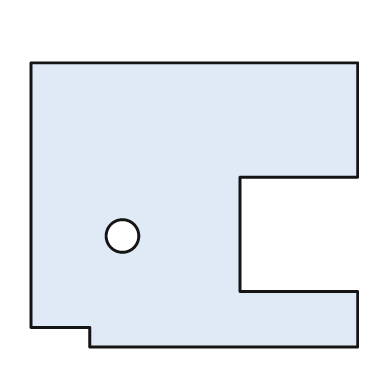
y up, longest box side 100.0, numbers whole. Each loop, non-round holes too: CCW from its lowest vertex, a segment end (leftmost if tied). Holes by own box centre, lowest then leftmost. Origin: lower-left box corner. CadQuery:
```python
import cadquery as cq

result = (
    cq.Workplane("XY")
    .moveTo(18.0, 0.0)
    .lineTo(100.0, 0.0)
    .lineTo(100.0, 17.0)
    .lineTo(64.0, 17.0)
    .lineTo(64.0, 52.0)
    .lineTo(100.0, 52.0)
    .lineTo(100.0, 87.0)
    .lineTo(0.0, 87.0)
    .lineTo(0.0, 6.0)
    .lineTo(18.0, 6.0)
    .close()
    .moveTo(28.0, 34.0)
    .circle(5.0)
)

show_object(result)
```